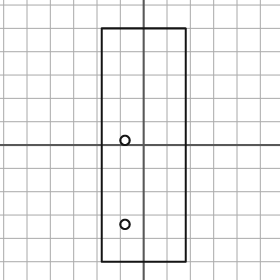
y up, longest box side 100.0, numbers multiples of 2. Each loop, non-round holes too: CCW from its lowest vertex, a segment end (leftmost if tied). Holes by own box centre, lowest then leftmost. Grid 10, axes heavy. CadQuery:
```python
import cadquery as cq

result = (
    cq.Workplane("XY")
    .moveTo(-18.0, -50.0)
    .lineTo(18.0, -50.0)
    .lineTo(18.0, 50.0)
    .lineTo(-18.0, 50.0)
    .close()
    .moveTo(-8.0, -34.0)
    .circle(2.0)
    .moveTo(-8.0, 2.0)
    .circle(2.0)
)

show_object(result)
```